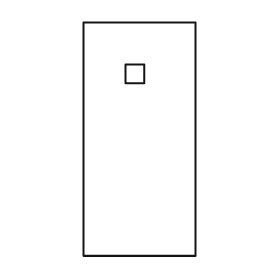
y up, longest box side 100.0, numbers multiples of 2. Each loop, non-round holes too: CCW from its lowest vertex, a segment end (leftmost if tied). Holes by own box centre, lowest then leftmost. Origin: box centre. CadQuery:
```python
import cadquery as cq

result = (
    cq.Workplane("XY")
    .moveTo(-24.0, -50.0)
    .lineTo(24.0, -50.0)
    .lineTo(24.0, 50.0)
    .lineTo(-24.0, 50.0)
    .close()
    .moveTo(-6.0, 24.0)
    .lineTo(2.0, 24.0)
    .lineTo(2.0, 32.0)
    .lineTo(-6.0, 32.0)
    .close()
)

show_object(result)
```